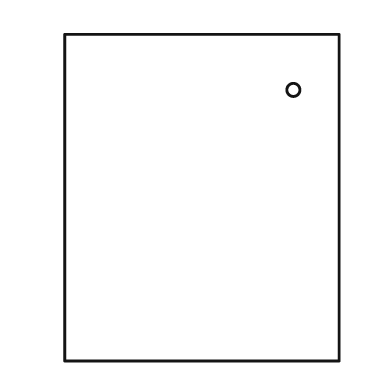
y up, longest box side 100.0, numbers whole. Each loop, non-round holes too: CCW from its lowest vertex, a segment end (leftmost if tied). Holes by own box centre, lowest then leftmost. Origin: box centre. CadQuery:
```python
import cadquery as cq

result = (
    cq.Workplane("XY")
    .moveTo(-42.0, -50.0)
    .lineTo(42.0, -50.0)
    .lineTo(42.0, 50.0)
    .lineTo(-42.0, 50.0)
    .close()
    .moveTo(28.0, 33.0)
    .circle(2.0)
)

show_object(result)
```